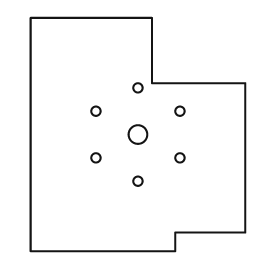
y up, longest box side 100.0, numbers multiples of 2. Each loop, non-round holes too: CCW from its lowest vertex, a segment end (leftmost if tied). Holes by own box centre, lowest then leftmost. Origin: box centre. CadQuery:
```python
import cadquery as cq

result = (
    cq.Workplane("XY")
    .moveTo(-46.0, -50.0)
    .lineTo(16.0, -50.0)
    .lineTo(16.0, -42.0)
    .lineTo(46.0, -42.0)
    .lineTo(46.0, 22.0)
    .lineTo(6.0, 22.0)
    .lineTo(6.0, 50.0)
    .lineTo(-46.0, 50.0)
    .close()
    .moveTo(0.0, -20.0)
    .circle(2.0)
    .moveTo(-18.0, -10.0)
    .circle(2.0)
    .moveTo(18.0, -10.0)
    .circle(2.0)
    .moveTo(0.0, 0.0)
    .circle(4.0)
    .moveTo(-18.0, 10.0)
    .circle(2.0)
    .moveTo(18.0, 10.0)
    .circle(2.0)
    .moveTo(0.0, 20.0)
    .circle(2.0)
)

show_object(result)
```